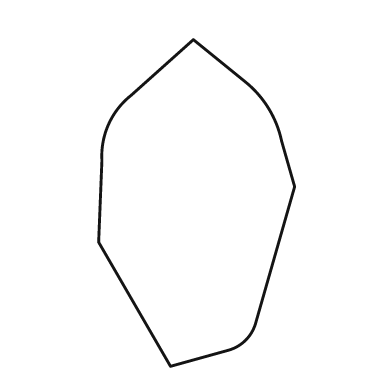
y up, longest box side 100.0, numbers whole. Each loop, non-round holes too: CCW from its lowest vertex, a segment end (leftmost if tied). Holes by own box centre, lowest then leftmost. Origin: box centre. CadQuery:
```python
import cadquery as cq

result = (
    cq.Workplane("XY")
    .moveTo(-8.0, -50.0)
    .lineTo(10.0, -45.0)
    .threePointArc((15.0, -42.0), (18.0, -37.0))
    .lineTo(30.0, 5.0)
    .lineTo(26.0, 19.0)
    .threePointArc((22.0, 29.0), (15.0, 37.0))
    .lineTo(-1.0, 50.0)
    .lineTo(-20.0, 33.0)
    .threePointArc((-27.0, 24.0), (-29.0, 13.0))
    .lineTo(-30.0, -12.0)
    .close()
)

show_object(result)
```